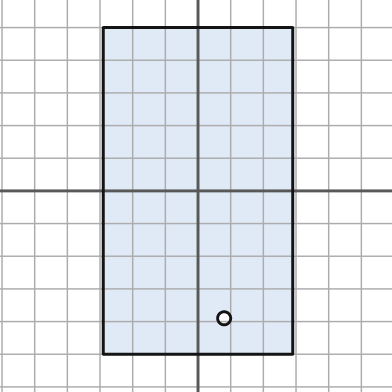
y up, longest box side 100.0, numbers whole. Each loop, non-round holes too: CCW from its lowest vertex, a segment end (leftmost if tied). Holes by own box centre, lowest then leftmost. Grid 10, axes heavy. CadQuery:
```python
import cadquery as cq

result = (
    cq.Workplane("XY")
    .moveTo(-29.0, -50.0)
    .lineTo(29.0, -50.0)
    .lineTo(29.0, 50.0)
    .lineTo(-29.0, 50.0)
    .close()
    .moveTo(8.0, -39.0)
    .circle(2.0)
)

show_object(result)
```